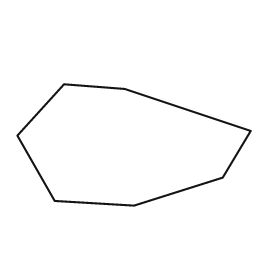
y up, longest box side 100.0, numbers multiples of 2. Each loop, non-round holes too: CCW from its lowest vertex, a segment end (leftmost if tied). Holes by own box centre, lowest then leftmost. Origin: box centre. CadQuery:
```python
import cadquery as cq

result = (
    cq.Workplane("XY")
    .moveTo(0.0, -26.0)
    .lineTo(38.0, -14.0)
    .lineTo(50.0, 6.0)
    .lineTo(-4.0, 24.0)
    .lineTo(-30.0, 26.0)
    .lineTo(-50.0, 4.0)
    .lineTo(-34.0, -24.0)
    .close()
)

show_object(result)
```